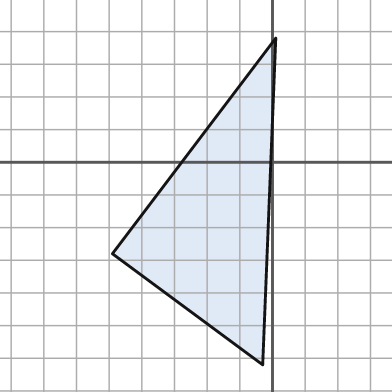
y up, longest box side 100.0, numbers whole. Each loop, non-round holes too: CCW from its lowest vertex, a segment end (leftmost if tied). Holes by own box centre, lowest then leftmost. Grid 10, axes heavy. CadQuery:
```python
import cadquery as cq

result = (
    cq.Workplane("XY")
    .moveTo(-3.0, -62.0)
    .lineTo(1.0, 38.0)
    .lineTo(-49.0, -28.0)
    .close()
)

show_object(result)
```